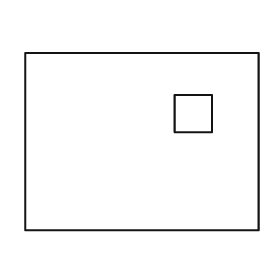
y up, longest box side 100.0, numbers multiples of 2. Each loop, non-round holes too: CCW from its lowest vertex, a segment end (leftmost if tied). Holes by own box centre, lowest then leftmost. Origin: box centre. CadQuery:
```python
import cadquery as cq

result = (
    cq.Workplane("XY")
    .moveTo(-50.0, -38.0)
    .lineTo(50.0, -38.0)
    .lineTo(50.0, 38.0)
    .lineTo(-50.0, 38.0)
    .close()
    .moveTo(14.0, 4.0)
    .lineTo(30.0, 4.0)
    .lineTo(30.0, 20.0)
    .lineTo(14.0, 20.0)
    .close()
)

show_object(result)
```